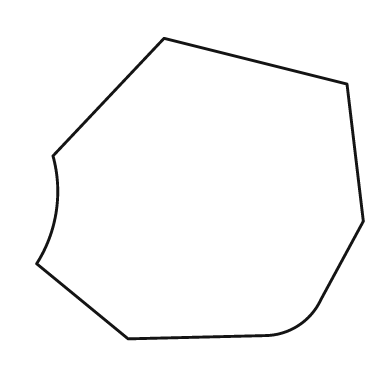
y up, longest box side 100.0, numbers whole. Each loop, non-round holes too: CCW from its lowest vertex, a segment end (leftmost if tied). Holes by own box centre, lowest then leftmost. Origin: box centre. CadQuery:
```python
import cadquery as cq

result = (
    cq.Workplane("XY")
    .moveTo(-22.0, -46.0)
    .lineTo(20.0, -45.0)
    .threePointArc((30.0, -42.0), (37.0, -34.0))
    .lineTo(50.0, -10.0)
    .lineTo(45.0, 32.0)
    .lineTo(-11.0, 46.0)
    .lineTo(-45.0, 10.0)
    .threePointArc((-44.0, -7.0), (-50.0, -23.0))
    .close()
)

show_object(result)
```